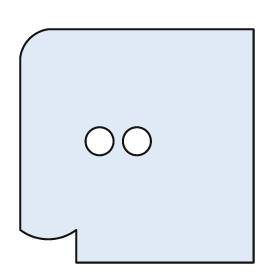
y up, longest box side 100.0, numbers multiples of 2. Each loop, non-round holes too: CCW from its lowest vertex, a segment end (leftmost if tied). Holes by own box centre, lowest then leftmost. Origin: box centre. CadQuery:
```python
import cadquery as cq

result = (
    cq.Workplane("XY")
    .moveTo(-26.0, -50.0)
    .lineTo(50.0, -50.0)
    .lineTo(50.0, 50.0)
    .lineTo(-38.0, 50.0)
    .threePointArc((-46.0, 46.0), (-50.0, 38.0))
    .lineTo(-50.0, -36.0)
    .threePointArc((-38.0, -40.0), (-26.0, -36.0))
    .close()
    .moveTo(-16.0, 2.0)
    .circle(6.0)
    .moveTo(0.0, 2.0)
    .circle(6.0)
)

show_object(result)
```